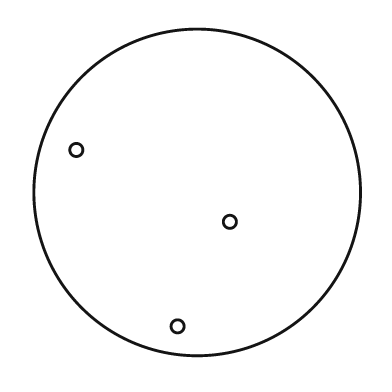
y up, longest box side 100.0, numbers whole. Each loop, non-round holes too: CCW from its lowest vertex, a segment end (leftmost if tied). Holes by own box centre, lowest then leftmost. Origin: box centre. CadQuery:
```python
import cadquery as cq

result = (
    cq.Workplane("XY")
    .moveTo(0.0, 0.0)
    .circle(50.0)
    .moveTo(-6.0, -41.0)
    .circle(2.0)
    .moveTo(10.0, -9.0)
    .circle(2.0)
    .moveTo(-37.0, 13.0)
    .circle(2.0)
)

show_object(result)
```